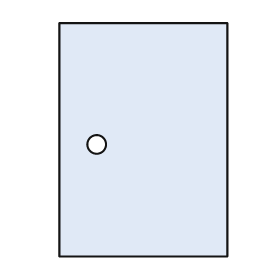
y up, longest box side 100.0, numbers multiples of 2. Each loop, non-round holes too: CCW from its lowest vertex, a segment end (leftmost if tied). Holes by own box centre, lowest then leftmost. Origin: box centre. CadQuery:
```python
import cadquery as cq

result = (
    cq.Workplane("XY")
    .moveTo(-36.0, -50.0)
    .lineTo(36.0, -50.0)
    .lineTo(36.0, 50.0)
    .lineTo(-36.0, 50.0)
    .close()
    .moveTo(-20.0, -2.0)
    .circle(4.0)
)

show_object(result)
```